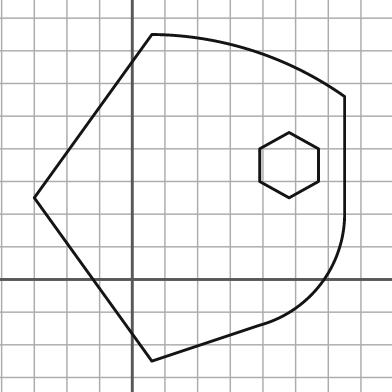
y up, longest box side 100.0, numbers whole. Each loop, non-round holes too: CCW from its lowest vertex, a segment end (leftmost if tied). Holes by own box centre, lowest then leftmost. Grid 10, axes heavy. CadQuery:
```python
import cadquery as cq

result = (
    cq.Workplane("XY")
    .moveTo(6.0, -25.0)
    .lineTo(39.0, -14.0)
    .threePointArc((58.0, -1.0), (65.0, 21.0))
    .lineTo(65.0, 56.0)
    .threePointArc((37.0, 70.0), (6.0, 75.0))
    .lineTo(-30.0, 25.0)
    .close()
    .moveTo(48.0, 25.0)
    .lineTo(57.0, 30.0)
    .lineTo(57.0, 40.0)
    .lineTo(48.0, 45.0)
    .lineTo(39.0, 40.0)
    .lineTo(39.0, 30.0)
    .close()
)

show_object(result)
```